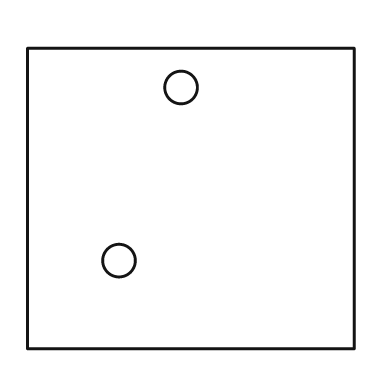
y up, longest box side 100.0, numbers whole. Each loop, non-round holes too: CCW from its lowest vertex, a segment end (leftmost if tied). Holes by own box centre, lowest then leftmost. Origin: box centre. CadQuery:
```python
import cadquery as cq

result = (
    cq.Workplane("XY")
    .moveTo(-50.0, -46.0)
    .lineTo(50.0, -46.0)
    .lineTo(50.0, 46.0)
    .lineTo(-50.0, 46.0)
    .close()
    .moveTo(-22.0, -19.0)
    .circle(5.0)
    .moveTo(-3.0, 34.0)
    .circle(5.0)
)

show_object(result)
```